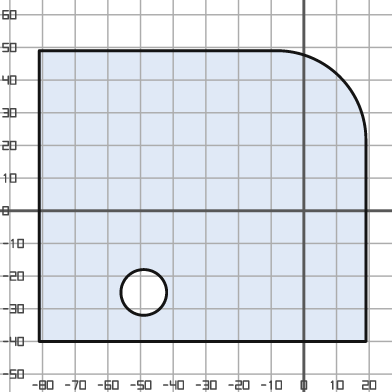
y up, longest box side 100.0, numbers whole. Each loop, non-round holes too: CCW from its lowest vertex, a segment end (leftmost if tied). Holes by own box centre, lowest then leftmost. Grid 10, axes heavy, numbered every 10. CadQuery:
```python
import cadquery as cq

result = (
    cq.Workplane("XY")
    .moveTo(-81.0, -40.0)
    .lineTo(19.0, -40.0)
    .lineTo(19.0, 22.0)
    .threePointArc((11.0, 41.0), (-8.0, 49.0))
    .lineTo(-81.0, 49.0)
    .close()
    .moveTo(-49.0, -25.0)
    .circle(7.0)
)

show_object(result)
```